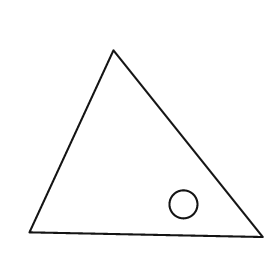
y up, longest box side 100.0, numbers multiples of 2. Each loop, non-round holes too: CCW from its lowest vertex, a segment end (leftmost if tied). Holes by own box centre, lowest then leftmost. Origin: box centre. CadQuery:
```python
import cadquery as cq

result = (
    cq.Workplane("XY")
    .moveTo(50.0, -40.0)
    .lineTo(-14.0, 40.0)
    .lineTo(-50.0, -38.0)
    .close()
    .moveTo(16.0, -26.0)
    .circle(6.0)
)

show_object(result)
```